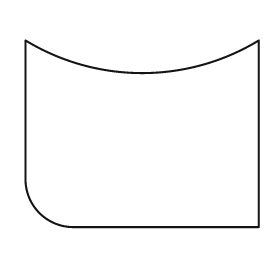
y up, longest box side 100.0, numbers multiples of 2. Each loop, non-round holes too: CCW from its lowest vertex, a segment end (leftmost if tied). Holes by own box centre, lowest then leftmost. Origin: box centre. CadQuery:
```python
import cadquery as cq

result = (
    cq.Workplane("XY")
    .moveTo(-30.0, -40.0)
    .lineTo(50.0, -40.0)
    .lineTo(50.0, 40.0)
    .threePointArc((0.0, 26.0), (-50.0, 40.0))
    .lineTo(-50.0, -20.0)
    .threePointArc((-44.0, -34.0), (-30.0, -40.0))
    .close()
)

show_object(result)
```